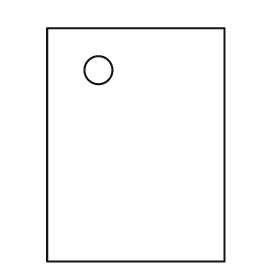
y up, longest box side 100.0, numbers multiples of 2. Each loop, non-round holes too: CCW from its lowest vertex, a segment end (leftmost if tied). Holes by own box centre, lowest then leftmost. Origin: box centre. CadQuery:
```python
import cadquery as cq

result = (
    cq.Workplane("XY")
    .moveTo(-38.0, -50.0)
    .lineTo(38.0, -50.0)
    .lineTo(38.0, 50.0)
    .lineTo(-38.0, 50.0)
    .close()
    .moveTo(-16.0, 32.0)
    .circle(6.0)
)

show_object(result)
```